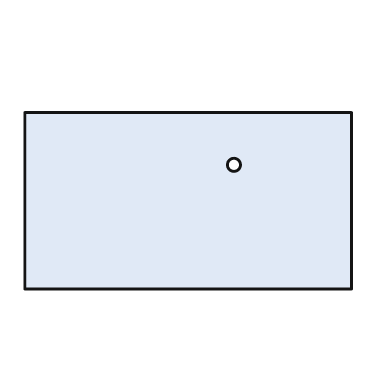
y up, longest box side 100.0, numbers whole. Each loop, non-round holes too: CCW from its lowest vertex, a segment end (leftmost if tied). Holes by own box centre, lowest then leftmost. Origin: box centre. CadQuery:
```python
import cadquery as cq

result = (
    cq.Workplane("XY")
    .moveTo(-50.0, -27.0)
    .lineTo(50.0, -27.0)
    .lineTo(50.0, 27.0)
    .lineTo(-50.0, 27.0)
    .close()
    .moveTo(14.0, 11.0)
    .circle(2.0)
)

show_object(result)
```